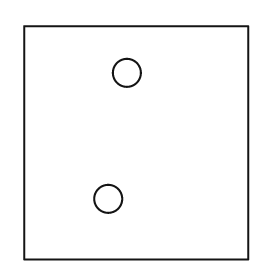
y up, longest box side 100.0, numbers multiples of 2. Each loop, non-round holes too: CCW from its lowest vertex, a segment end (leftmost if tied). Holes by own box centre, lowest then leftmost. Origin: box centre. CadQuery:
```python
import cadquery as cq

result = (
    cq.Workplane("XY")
    .moveTo(-48.0, -50.0)
    .lineTo(48.0, -50.0)
    .lineTo(48.0, 50.0)
    .lineTo(-48.0, 50.0)
    .close()
    .moveTo(-12.0, -24.0)
    .circle(6.0)
    .moveTo(-4.0, 30.0)
    .circle(6.0)
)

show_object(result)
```